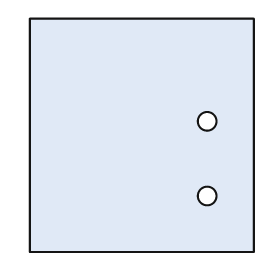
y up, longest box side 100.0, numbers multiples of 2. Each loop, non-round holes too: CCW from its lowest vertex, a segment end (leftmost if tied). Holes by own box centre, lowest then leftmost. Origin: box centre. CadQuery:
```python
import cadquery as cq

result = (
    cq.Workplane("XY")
    .moveTo(-48.0, -50.0)
    .lineTo(48.0, -50.0)
    .lineTo(48.0, 50.0)
    .lineTo(-48.0, 50.0)
    .close()
    .moveTo(28.0, -26.0)
    .circle(4.0)
    .moveTo(28.0, 6.0)
    .circle(4.0)
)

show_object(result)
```